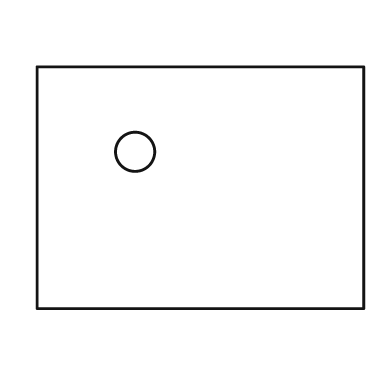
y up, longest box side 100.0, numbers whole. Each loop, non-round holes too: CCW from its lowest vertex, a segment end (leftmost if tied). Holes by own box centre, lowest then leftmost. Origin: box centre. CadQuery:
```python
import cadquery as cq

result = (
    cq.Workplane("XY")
    .moveTo(-50.0, -37.0)
    .lineTo(50.0, -37.0)
    .lineTo(50.0, 37.0)
    .lineTo(-50.0, 37.0)
    .close()
    .moveTo(-20.0, 11.0)
    .circle(6.0)
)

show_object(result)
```